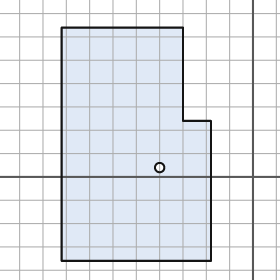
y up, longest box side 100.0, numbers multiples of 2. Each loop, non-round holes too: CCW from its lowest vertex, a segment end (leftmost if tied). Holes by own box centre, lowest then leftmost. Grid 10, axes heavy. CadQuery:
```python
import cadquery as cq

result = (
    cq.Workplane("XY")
    .moveTo(-82.0, -36.0)
    .lineTo(-18.0, -36.0)
    .lineTo(-18.0, 24.0)
    .lineTo(-30.0, 24.0)
    .lineTo(-30.0, 64.0)
    .lineTo(-82.0, 64.0)
    .close()
    .moveTo(-40.0, 4.0)
    .circle(2.0)
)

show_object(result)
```